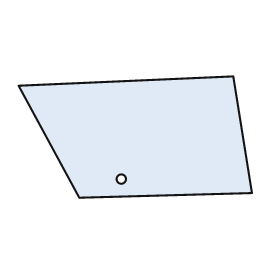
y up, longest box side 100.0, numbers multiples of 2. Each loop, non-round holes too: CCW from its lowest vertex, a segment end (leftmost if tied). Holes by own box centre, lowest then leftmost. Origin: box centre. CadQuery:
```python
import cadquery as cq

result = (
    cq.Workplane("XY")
    .moveTo(-24.0, -26.0)
    .lineTo(50.0, -24.0)
    .lineTo(42.0, 26.0)
    .lineTo(-50.0, 22.0)
    .close()
    .moveTo(-6.0, -18.0)
    .circle(2.0)
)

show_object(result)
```